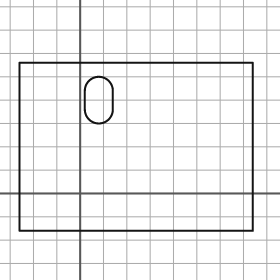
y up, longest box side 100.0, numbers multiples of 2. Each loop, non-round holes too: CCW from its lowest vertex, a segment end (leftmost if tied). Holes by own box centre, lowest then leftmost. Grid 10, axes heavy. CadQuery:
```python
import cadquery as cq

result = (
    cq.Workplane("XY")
    .moveTo(-26.0, -16.0)
    .lineTo(74.0, -16.0)
    .lineTo(74.0, 56.0)
    .lineTo(-26.0, 56.0)
    .close()
    .moveTo(2.0, 36.0)
    .threePointArc((8.0, 30.0), (14.0, 36.0))
    .lineTo(14.0, 44.0)
    .threePointArc((8.0, 50.0), (2.0, 44.0))
    .close()
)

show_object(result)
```